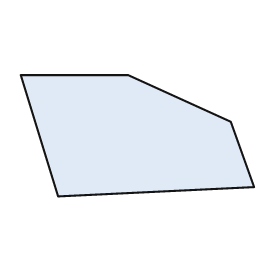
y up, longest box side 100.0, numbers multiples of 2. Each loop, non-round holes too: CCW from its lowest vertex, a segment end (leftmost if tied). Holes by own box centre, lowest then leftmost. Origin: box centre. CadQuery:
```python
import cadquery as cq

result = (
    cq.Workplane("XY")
    .moveTo(-34.0, -26.0)
    .lineTo(50.0, -22.0)
    .lineTo(40.0, 6.0)
    .lineTo(-4.0, 26.0)
    .lineTo(-50.0, 26.0)
    .close()
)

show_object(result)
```